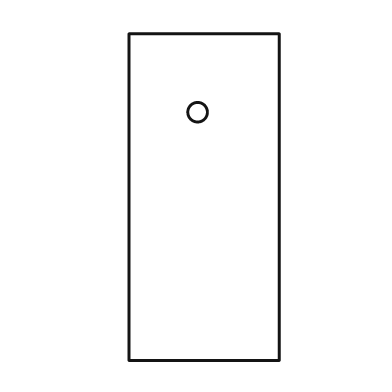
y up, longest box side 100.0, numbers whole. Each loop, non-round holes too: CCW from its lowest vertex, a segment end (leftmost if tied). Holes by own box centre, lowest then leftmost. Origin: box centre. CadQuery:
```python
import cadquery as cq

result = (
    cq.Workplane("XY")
    .moveTo(-23.0, -50.0)
    .lineTo(23.0, -50.0)
    .lineTo(23.0, 50.0)
    .lineTo(-23.0, 50.0)
    .close()
    .moveTo(-2.0, 26.0)
    .circle(3.0)
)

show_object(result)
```